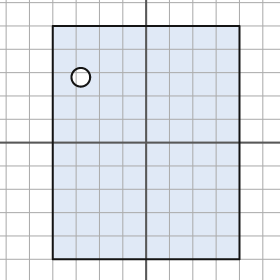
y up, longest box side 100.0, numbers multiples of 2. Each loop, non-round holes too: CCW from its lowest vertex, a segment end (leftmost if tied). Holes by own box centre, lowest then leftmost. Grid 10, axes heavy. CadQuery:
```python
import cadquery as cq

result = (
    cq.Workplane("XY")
    .moveTo(-40.0, -50.0)
    .lineTo(40.0, -50.0)
    .lineTo(40.0, 50.0)
    .lineTo(-40.0, 50.0)
    .close()
    .moveTo(-28.0, 28.0)
    .circle(4.0)
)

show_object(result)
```